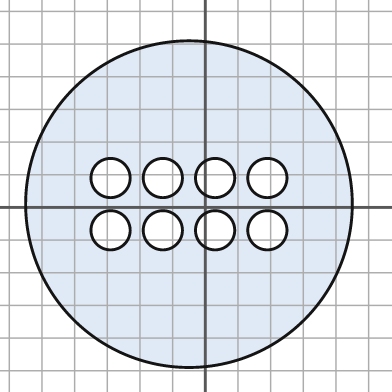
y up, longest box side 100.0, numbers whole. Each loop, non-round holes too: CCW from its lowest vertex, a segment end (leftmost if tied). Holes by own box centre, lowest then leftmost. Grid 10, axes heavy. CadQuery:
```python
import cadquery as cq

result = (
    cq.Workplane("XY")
    .moveTo(-5.0, 1.0)
    .circle(50.0)
    .moveTo(-29.0, -7.0)
    .circle(6.0)
    .moveTo(-13.0, -7.0)
    .circle(6.0)
    .moveTo(3.0, -7.0)
    .circle(6.0)
    .moveTo(19.0, -7.0)
    .circle(6.0)
    .moveTo(-29.0, 9.0)
    .circle(6.0)
    .moveTo(-13.0, 9.0)
    .circle(6.0)
    .moveTo(3.0, 9.0)
    .circle(6.0)
    .moveTo(19.0, 9.0)
    .circle(6.0)
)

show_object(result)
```